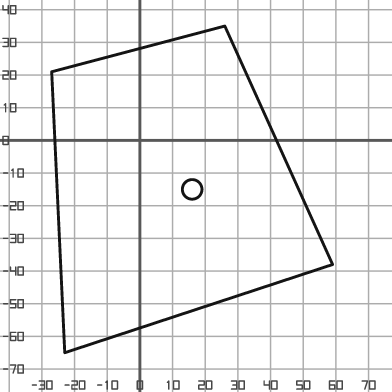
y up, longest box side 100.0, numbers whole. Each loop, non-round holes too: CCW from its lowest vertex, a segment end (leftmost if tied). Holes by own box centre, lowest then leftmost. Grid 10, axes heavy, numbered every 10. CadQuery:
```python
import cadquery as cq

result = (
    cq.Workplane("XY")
    .moveTo(-23.0, -65.0)
    .lineTo(59.0, -38.0)
    .lineTo(26.0, 35.0)
    .lineTo(-27.0, 21.0)
    .close()
    .moveTo(16.0, -15.0)
    .circle(3.0)
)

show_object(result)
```